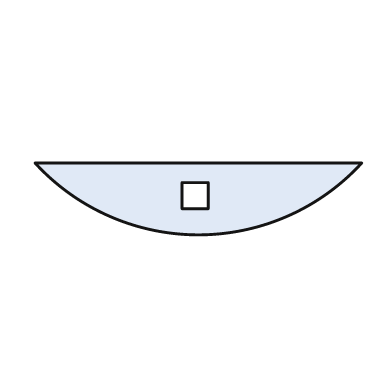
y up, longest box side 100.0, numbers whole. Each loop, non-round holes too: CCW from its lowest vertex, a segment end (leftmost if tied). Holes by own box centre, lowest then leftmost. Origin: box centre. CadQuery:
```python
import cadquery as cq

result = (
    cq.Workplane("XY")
    .moveTo(-50.0, 11.0)
    .threePointArc((0.0, -11.0), (50.0, 11.0))
    .close()
    .moveTo(-5.0, -3.0)
    .lineTo(3.0, -3.0)
    .lineTo(3.0, 5.0)
    .lineTo(-5.0, 5.0)
    .close()
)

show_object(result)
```